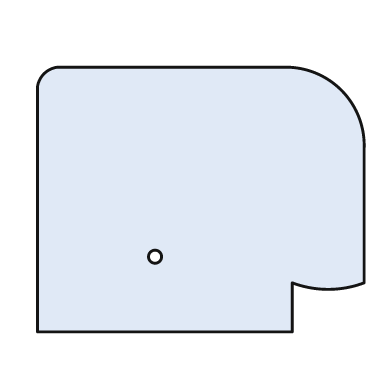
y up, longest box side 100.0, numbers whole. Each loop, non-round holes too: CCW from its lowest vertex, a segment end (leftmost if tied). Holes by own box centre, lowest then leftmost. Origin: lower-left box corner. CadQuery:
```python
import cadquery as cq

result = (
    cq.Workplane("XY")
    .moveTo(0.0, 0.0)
    .lineTo(78.0, 0.0)
    .lineTo(78.0, 15.0)
    .threePointArc((89.0, 13.0), (100.0, 15.0))
    .lineTo(100.0, 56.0)
    .threePointArc((93.0, 74.0), (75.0, 81.0))
    .lineTo(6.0, 81.0)
    .threePointArc((2.0, 79.0), (0.0, 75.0))
    .close()
    .moveTo(36.0, 23.0)
    .circle(2.0)
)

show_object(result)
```